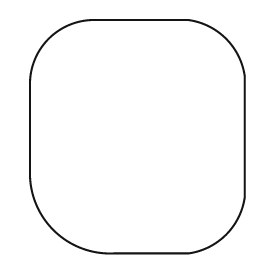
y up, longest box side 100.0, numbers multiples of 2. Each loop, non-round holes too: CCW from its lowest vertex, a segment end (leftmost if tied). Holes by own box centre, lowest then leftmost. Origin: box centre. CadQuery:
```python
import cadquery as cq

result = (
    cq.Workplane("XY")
    .moveTo(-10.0, -50.0)
    .lineTo(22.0, -50.0)
    .threePointArc((38.0, -42.0), (46.0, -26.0))
    .lineTo(46.0, 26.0)
    .threePointArc((38.0, 42.0), (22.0, 50.0))
    .lineTo(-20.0, 50.0)
    .threePointArc((-38.0, 42.0), (-46.0, 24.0))
    .lineTo(-46.0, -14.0)
    .threePointArc((-36.0, -40.0), (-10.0, -50.0))
    .close()
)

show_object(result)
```